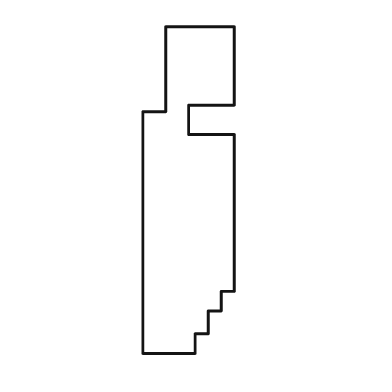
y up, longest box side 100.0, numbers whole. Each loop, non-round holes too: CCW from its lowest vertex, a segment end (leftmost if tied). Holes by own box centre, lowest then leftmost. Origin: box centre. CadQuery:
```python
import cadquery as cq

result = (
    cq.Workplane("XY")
    .moveTo(-14.0, -50.0)
    .lineTo(2.0, -50.0)
    .lineTo(2.0, -44.0)
    .lineTo(6.0, -44.0)
    .lineTo(6.0, -37.0)
    .lineTo(10.0, -37.0)
    .lineTo(10.0, -31.0)
    .lineTo(14.0, -31.0)
    .lineTo(14.0, 17.0)
    .lineTo(0.0, 17.0)
    .lineTo(0.0, 26.0)
    .lineTo(14.0, 26.0)
    .lineTo(14.0, 50.0)
    .lineTo(-7.0, 50.0)
    .lineTo(-7.0, 24.0)
    .lineTo(-14.0, 24.0)
    .close()
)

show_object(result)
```